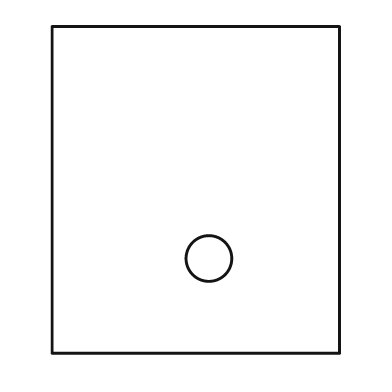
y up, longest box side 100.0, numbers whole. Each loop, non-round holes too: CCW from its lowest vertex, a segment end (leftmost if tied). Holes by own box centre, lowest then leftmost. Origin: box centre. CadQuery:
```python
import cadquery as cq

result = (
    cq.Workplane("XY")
    .moveTo(-44.0, -50.0)
    .lineTo(44.0, -50.0)
    .lineTo(44.0, 50.0)
    .lineTo(-44.0, 50.0)
    .close()
    .moveTo(4.0, -21.0)
    .circle(7.0)
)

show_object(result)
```